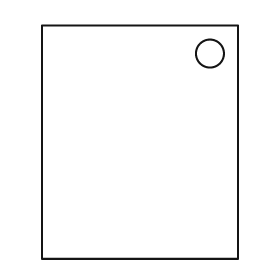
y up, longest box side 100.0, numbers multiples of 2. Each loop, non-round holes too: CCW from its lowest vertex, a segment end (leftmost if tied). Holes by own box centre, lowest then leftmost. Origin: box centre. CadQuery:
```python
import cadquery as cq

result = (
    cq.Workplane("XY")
    .moveTo(-42.0, -50.0)
    .lineTo(42.0, -50.0)
    .lineTo(42.0, 50.0)
    .lineTo(-42.0, 50.0)
    .close()
    .moveTo(30.0, 38.0)
    .circle(6.0)
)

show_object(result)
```